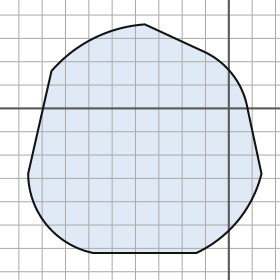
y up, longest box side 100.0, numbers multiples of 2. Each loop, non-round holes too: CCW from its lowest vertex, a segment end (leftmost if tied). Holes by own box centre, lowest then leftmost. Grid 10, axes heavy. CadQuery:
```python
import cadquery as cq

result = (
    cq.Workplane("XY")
    .moveTo(-58.0, -62.0)
    .lineTo(-14.0, -62.0)
    .threePointArc((4.0, -48.0), (14.0, -28.0))
    .lineTo(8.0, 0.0)
    .threePointArc((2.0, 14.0), (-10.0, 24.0))
    .lineTo(-36.0, 36.0)
    .threePointArc((-58.0, 30.0), (-76.0, 16.0))
    .lineTo(-86.0, -28.0)
    .threePointArc((-78.0, -50.0), (-58.0, -62.0))
    .close()
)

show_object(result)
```